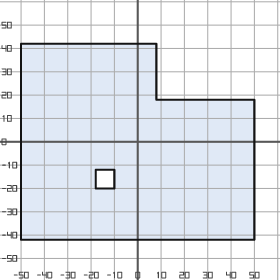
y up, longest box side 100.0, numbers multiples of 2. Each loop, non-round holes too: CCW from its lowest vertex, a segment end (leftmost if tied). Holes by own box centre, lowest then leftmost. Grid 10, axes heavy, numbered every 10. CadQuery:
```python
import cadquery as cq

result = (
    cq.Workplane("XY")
    .moveTo(-50.0, -42.0)
    .lineTo(50.0, -42.0)
    .lineTo(50.0, 18.0)
    .lineTo(8.0, 18.0)
    .lineTo(8.0, 42.0)
    .lineTo(-50.0, 42.0)
    .close()
    .moveTo(-18.0, -20.0)
    .lineTo(-10.0, -20.0)
    .lineTo(-10.0, -12.0)
    .lineTo(-18.0, -12.0)
    .close()
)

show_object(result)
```